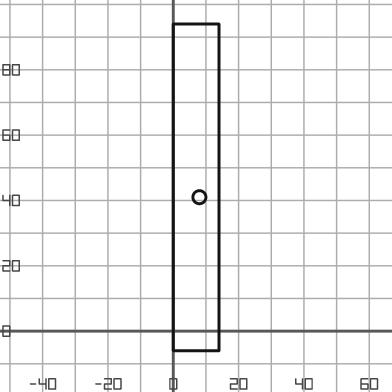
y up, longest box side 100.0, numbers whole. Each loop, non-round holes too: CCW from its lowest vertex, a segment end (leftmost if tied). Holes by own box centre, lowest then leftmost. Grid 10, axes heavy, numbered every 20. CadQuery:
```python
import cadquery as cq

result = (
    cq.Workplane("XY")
    .moveTo(0.0, -6.0)
    .lineTo(14.0, -6.0)
    .lineTo(14.0, 94.0)
    .lineTo(0.0, 94.0)
    .close()
    .moveTo(8.0, 41.0)
    .circle(2.0)
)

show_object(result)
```